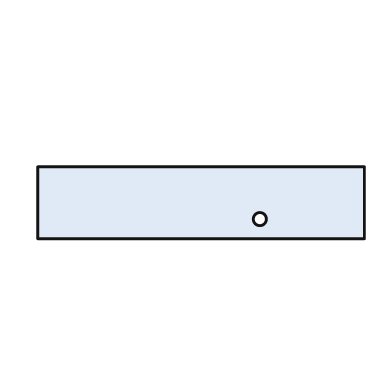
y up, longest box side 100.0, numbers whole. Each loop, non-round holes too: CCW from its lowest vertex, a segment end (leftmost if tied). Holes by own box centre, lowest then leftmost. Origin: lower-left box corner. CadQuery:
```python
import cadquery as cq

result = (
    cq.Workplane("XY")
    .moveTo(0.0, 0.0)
    .lineTo(100.0, 0.0)
    .lineTo(100.0, 22.0)
    .lineTo(0.0, 22.0)
    .close()
    .moveTo(68.0, 6.0)
    .circle(2.0)
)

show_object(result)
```